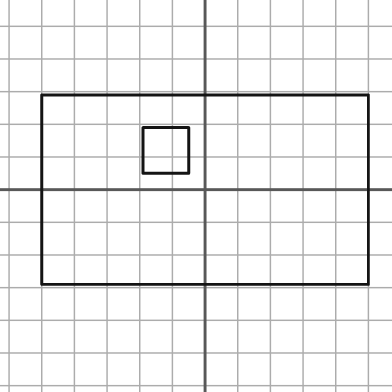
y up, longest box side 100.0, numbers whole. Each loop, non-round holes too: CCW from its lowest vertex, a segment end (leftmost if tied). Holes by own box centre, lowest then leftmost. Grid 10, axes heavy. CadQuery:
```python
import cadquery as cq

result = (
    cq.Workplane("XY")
    .moveTo(-50.0, -29.0)
    .lineTo(50.0, -29.0)
    .lineTo(50.0, 29.0)
    .lineTo(-50.0, 29.0)
    .close()
    .moveTo(-19.0, 5.0)
    .lineTo(-5.0, 5.0)
    .lineTo(-5.0, 19.0)
    .lineTo(-19.0, 19.0)
    .close()
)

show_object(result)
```